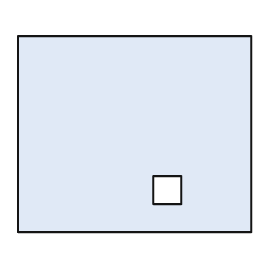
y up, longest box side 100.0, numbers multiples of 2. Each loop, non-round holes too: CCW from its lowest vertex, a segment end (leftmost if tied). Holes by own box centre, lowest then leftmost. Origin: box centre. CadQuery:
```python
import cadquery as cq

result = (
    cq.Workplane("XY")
    .moveTo(-50.0, -42.0)
    .lineTo(50.0, -42.0)
    .lineTo(50.0, 42.0)
    .lineTo(-50.0, 42.0)
    .close()
    .moveTo(8.0, -30.0)
    .lineTo(20.0, -30.0)
    .lineTo(20.0, -18.0)
    .lineTo(8.0, -18.0)
    .close()
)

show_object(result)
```